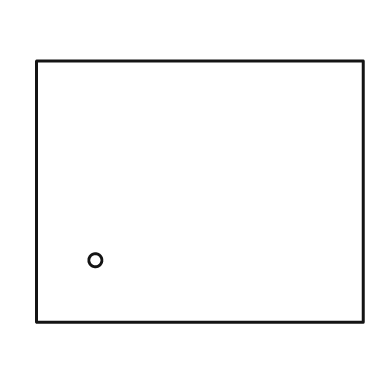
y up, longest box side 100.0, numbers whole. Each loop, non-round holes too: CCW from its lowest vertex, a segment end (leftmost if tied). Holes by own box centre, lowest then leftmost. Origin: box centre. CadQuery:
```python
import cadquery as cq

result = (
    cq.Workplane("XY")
    .moveTo(-50.0, -40.0)
    .lineTo(50.0, -40.0)
    .lineTo(50.0, 40.0)
    .lineTo(-50.0, 40.0)
    .close()
    .moveTo(-32.0, -21.0)
    .circle(2.0)
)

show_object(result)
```